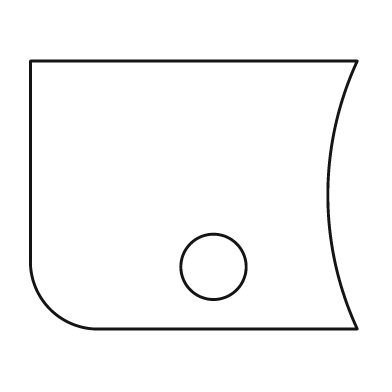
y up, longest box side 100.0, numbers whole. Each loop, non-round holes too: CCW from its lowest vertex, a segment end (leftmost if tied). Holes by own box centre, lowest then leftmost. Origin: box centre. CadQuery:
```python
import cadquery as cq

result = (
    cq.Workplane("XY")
    .moveTo(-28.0, -41.0)
    .lineTo(50.0, -41.0)
    .threePointArc((41.0, 0.0), (50.0, 41.0))
    .lineTo(-50.0, 41.0)
    .lineTo(-50.0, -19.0)
    .threePointArc((-44.0, -35.0), (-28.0, -41.0))
    .close()
    .moveTo(6.0, -22.0)
    .circle(10.0)
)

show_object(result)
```